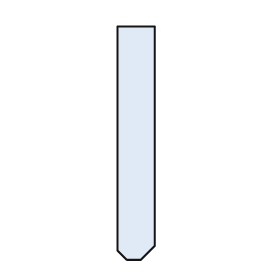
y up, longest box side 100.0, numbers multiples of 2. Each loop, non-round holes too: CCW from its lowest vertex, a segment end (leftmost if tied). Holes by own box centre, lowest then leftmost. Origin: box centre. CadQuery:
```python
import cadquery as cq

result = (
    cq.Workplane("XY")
    .moveTo(-4.0, -50.0)
    .lineTo(2.0, -50.0)
    .lineTo(8.0, -44.0)
    .lineTo(8.0, 50.0)
    .lineTo(-8.0, 50.0)
    .lineTo(-8.0, -46.0)
    .close()
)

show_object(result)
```